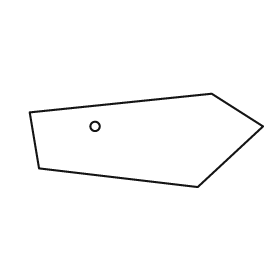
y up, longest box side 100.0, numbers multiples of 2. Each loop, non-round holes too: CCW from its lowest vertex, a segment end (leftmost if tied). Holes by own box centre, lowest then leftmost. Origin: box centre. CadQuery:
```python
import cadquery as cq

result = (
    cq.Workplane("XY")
    .moveTo(22.0, -20.0)
    .lineTo(50.0, 6.0)
    .lineTo(28.0, 20.0)
    .lineTo(-50.0, 12.0)
    .lineTo(-46.0, -12.0)
    .close()
    .moveTo(-22.0, 6.0)
    .circle(2.0)
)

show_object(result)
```